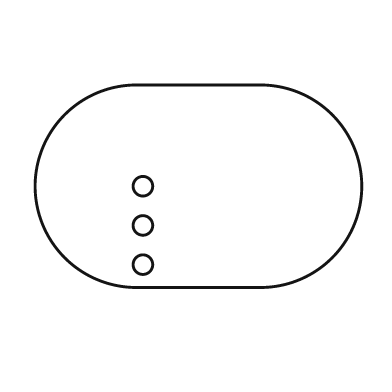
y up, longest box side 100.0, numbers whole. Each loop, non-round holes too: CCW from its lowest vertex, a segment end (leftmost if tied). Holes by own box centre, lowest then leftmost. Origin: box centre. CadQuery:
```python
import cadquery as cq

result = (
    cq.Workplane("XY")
    .moveTo(-19.0, -31.0)
    .lineTo(19.0, -31.0)
    .threePointArc((50.0, 0.0), (19.0, 31.0))
    .lineTo(-19.0, 31.0)
    .threePointArc((-50.0, 0.0), (-19.0, -31.0))
    .close()
    .moveTo(-17.0, -24.0)
    .circle(3.0)
    .moveTo(-17.0, -12.0)
    .circle(3.0)
    .moveTo(-17.0, 0.0)
    .circle(3.0)
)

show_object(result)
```